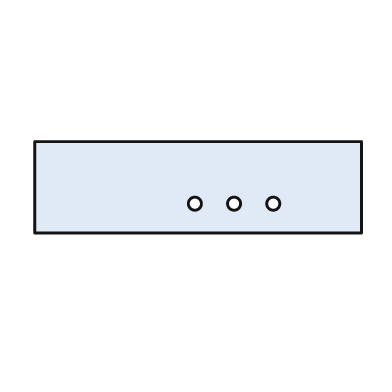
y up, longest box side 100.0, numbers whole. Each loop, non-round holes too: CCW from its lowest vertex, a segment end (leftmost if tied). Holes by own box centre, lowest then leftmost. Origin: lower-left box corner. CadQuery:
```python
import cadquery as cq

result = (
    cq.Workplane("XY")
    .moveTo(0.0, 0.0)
    .lineTo(100.0, 0.0)
    .lineTo(100.0, 28.0)
    .lineTo(0.0, 28.0)
    .close()
    .moveTo(49.0, 9.0)
    .circle(2.0)
    .moveTo(61.0, 9.0)
    .circle(2.0)
    .moveTo(73.0, 9.0)
    .circle(2.0)
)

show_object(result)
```